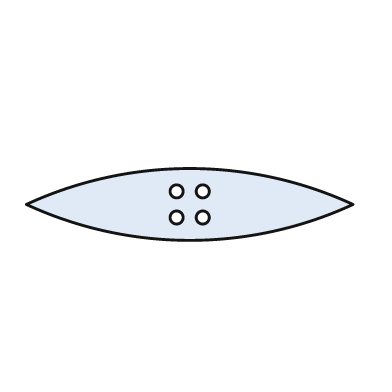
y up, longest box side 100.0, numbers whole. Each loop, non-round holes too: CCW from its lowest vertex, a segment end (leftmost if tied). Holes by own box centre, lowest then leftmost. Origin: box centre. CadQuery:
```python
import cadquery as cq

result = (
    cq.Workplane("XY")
    .moveTo(-50.0, 0.0)
    .threePointArc((0.0, -11.0), (50.0, 0.0))
    .threePointArc((0.0, 11.0), (-50.0, 0.0))
    .close()
    .moveTo(-4.0, -4.0)
    .circle(2.0)
    .moveTo(4.0, -4.0)
    .circle(2.0)
    .moveTo(-4.0, 4.0)
    .circle(2.0)
    .moveTo(4.0, 4.0)
    .circle(2.0)
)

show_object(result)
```